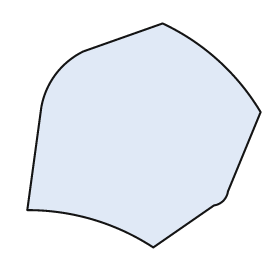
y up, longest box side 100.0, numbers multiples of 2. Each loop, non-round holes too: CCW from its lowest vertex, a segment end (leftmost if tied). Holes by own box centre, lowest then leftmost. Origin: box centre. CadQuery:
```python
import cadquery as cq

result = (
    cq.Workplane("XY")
    .moveTo(4.0, -48.0)
    .lineTo(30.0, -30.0)
    .threePointArc((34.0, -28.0), (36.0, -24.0))
    .lineTo(50.0, 10.0)
    .threePointArc((32.0, 32.0), (8.0, 48.0))
    .lineTo(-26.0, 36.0)
    .threePointArc((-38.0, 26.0), (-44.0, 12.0))
    .lineTo(-50.0, -32.0)
    .threePointArc((-22.0, -36.0), (4.0, -48.0))
    .close()
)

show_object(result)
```